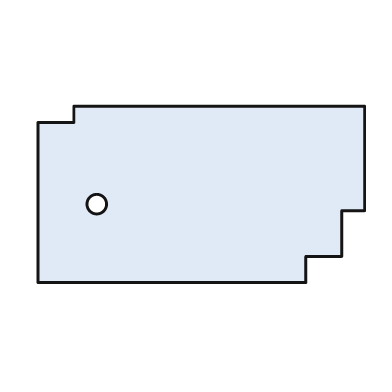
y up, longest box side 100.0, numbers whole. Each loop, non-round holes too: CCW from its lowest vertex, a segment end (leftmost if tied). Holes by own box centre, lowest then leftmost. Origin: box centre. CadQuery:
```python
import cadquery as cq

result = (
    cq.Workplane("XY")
    .moveTo(-50.0, -27.0)
    .lineTo(32.0, -27.0)
    .lineTo(32.0, -19.0)
    .lineTo(43.0, -19.0)
    .lineTo(43.0, -5.0)
    .lineTo(50.0, -5.0)
    .lineTo(50.0, 27.0)
    .lineTo(-39.0, 27.0)
    .lineTo(-39.0, 22.0)
    .lineTo(-50.0, 22.0)
    .close()
    .moveTo(-32.0, -3.0)
    .circle(3.0)
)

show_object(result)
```